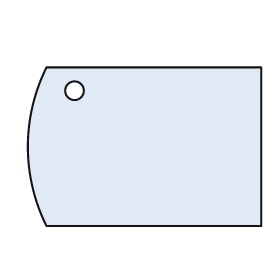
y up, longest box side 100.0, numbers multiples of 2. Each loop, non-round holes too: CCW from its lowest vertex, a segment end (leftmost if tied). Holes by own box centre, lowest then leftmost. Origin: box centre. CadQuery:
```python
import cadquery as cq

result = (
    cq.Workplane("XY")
    .moveTo(-42.0, -34.0)
    .lineTo(50.0, -34.0)
    .lineTo(50.0, 34.0)
    .lineTo(-42.0, 34.0)
    .threePointArc((-50.0, 0.0), (-42.0, -34.0))
    .close()
    .moveTo(-30.0, 24.0)
    .circle(4.0)
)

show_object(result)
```